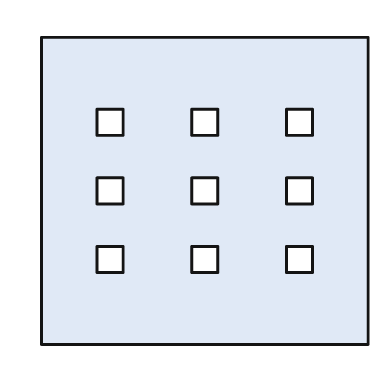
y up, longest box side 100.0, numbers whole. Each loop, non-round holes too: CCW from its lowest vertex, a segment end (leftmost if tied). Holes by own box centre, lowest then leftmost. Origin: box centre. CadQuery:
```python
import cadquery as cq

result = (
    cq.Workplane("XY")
    .moveTo(-50.0, -47.0)
    .lineTo(50.0, -47.0)
    .lineTo(50.0, 47.0)
    .lineTo(-50.0, 47.0)
    .close()
    .moveTo(-33.0, -25.0)
    .lineTo(-25.0, -25.0)
    .lineTo(-25.0, -17.0)
    .lineTo(-33.0, -17.0)
    .close()
    .moveTo(-4.0, -25.0)
    .lineTo(4.0, -25.0)
    .lineTo(4.0, -17.0)
    .lineTo(-4.0, -17.0)
    .close()
    .moveTo(25.0, -25.0)
    .lineTo(33.0, -25.0)
    .lineTo(33.0, -17.0)
    .lineTo(25.0, -17.0)
    .close()
    .moveTo(-33.0, -4.0)
    .lineTo(-25.0, -4.0)
    .lineTo(-25.0, 4.0)
    .lineTo(-33.0, 4.0)
    .close()
    .moveTo(-4.0, -4.0)
    .lineTo(4.0, -4.0)
    .lineTo(4.0, 4.0)
    .lineTo(-4.0, 4.0)
    .close()
    .moveTo(25.0, -4.0)
    .lineTo(33.0, -4.0)
    .lineTo(33.0, 4.0)
    .lineTo(25.0, 4.0)
    .close()
    .moveTo(-33.0, 17.0)
    .lineTo(-25.0, 17.0)
    .lineTo(-25.0, 25.0)
    .lineTo(-33.0, 25.0)
    .close()
    .moveTo(-4.0, 17.0)
    .lineTo(4.0, 17.0)
    .lineTo(4.0, 25.0)
    .lineTo(-4.0, 25.0)
    .close()
    .moveTo(25.0, 17.0)
    .lineTo(33.0, 17.0)
    .lineTo(33.0, 25.0)
    .lineTo(25.0, 25.0)
    .close()
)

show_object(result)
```